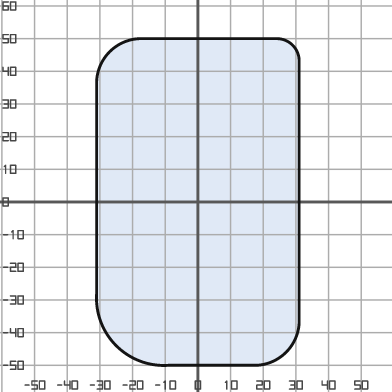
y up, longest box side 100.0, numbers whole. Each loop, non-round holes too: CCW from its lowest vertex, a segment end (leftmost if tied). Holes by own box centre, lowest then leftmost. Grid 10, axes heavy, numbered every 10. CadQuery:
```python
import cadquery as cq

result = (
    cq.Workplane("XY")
    .moveTo(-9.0, -50.0)
    .lineTo(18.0, -50.0)
    .threePointArc((27.0, -46.0), (31.0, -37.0))
    .lineTo(31.0, 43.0)
    .threePointArc((29.0, 48.0), (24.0, 50.0))
    .lineTo(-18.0, 50.0)
    .threePointArc((-27.0, 46.0), (-31.0, 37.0))
    .lineTo(-31.0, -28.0)
    .threePointArc((-25.0, -44.0), (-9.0, -50.0))
    .close()
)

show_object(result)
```